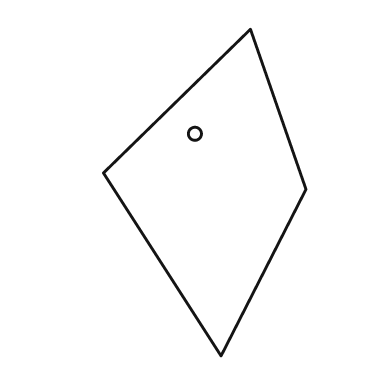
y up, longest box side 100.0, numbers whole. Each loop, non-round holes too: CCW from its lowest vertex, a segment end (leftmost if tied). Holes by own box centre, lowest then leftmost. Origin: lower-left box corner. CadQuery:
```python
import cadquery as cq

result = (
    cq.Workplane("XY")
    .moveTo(36.0, 0.0)
    .lineTo(62.0, 51.0)
    .lineTo(45.0, 100.0)
    .lineTo(0.0, 56.0)
    .close()
    .moveTo(28.0, 68.0)
    .circle(2.0)
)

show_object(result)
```